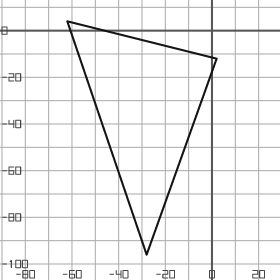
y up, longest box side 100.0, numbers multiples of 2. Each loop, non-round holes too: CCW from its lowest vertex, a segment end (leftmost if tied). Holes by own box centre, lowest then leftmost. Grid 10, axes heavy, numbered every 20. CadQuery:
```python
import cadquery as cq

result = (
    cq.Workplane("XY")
    .moveTo(-28.0, -96.0)
    .lineTo(2.0, -12.0)
    .lineTo(-62.0, 4.0)
    .close()
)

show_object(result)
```